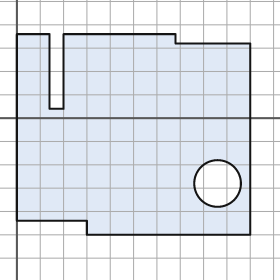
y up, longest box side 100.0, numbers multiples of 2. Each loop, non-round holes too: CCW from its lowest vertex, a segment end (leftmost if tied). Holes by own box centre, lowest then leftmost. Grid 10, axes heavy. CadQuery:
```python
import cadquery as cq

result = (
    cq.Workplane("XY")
    .moveTo(30.0, -50.0)
    .lineTo(100.0, -50.0)
    .lineTo(100.0, 32.0)
    .lineTo(68.0, 32.0)
    .lineTo(68.0, 36.0)
    .lineTo(20.0, 36.0)
    .lineTo(20.0, 4.0)
    .lineTo(14.0, 4.0)
    .lineTo(14.0, 36.0)
    .lineTo(0.0, 36.0)
    .lineTo(0.0, -44.0)
    .lineTo(30.0, -44.0)
    .close()
    .moveTo(86.0, -28.0)
    .circle(10.0)
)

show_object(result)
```